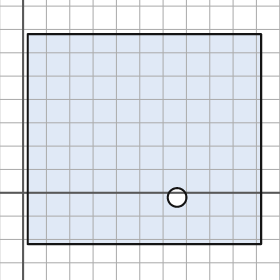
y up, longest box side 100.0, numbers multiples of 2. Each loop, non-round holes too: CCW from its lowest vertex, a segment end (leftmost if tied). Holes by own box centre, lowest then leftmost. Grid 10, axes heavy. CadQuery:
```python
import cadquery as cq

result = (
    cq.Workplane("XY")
    .moveTo(2.0, -22.0)
    .lineTo(102.0, -22.0)
    .lineTo(102.0, 68.0)
    .lineTo(2.0, 68.0)
    .close()
    .moveTo(66.0, -2.0)
    .circle(4.0)
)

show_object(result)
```